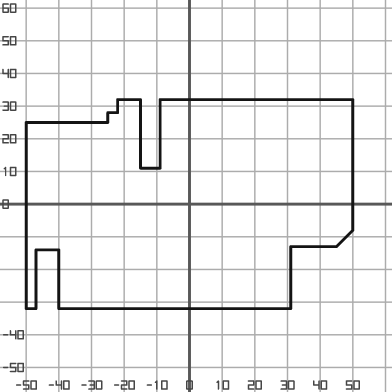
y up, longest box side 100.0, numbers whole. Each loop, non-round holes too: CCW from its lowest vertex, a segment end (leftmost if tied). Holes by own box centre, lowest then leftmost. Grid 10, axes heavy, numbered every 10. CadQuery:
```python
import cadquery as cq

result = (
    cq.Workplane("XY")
    .moveTo(-50.0, -32.0)
    .lineTo(-47.0, -32.0)
    .lineTo(-47.0, -14.0)
    .lineTo(-40.0, -14.0)
    .lineTo(-40.0, -32.0)
    .lineTo(31.0, -32.0)
    .lineTo(31.0, -13.0)
    .lineTo(45.0, -13.0)
    .lineTo(50.0, -8.0)
    .lineTo(50.0, 32.0)
    .lineTo(-9.0, 32.0)
    .lineTo(-9.0, 11.0)
    .lineTo(-15.0, 11.0)
    .lineTo(-15.0, 32.0)
    .lineTo(-22.0, 32.0)
    .lineTo(-22.0, 28.0)
    .lineTo(-25.0, 28.0)
    .lineTo(-25.0, 25.0)
    .lineTo(-50.0, 25.0)
    .close()
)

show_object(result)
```